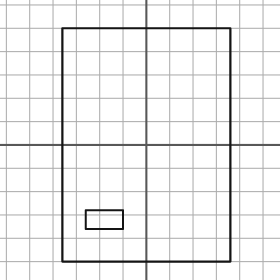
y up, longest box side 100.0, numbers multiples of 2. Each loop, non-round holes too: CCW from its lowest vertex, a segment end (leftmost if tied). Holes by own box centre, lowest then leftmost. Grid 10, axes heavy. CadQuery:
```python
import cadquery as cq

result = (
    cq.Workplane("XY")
    .moveTo(-36.0, -50.0)
    .lineTo(36.0, -50.0)
    .lineTo(36.0, 50.0)
    .lineTo(-36.0, 50.0)
    .close()
    .moveTo(-26.0, -36.0)
    .lineTo(-10.0, -36.0)
    .lineTo(-10.0, -28.0)
    .lineTo(-26.0, -28.0)
    .close()
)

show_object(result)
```